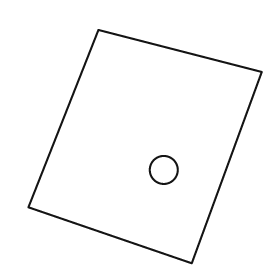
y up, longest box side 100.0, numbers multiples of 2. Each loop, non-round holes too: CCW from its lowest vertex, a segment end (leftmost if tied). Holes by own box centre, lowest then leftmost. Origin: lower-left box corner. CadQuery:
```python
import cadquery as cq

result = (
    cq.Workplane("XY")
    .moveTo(70.0, 0.0)
    .lineTo(100.0, 82.0)
    .lineTo(30.0, 100.0)
    .lineTo(0.0, 24.0)
    .close()
    .moveTo(58.0, 40.0)
    .circle(6.0)
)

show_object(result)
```